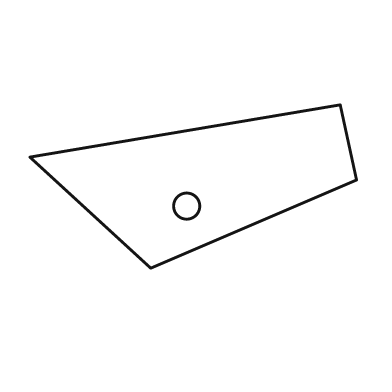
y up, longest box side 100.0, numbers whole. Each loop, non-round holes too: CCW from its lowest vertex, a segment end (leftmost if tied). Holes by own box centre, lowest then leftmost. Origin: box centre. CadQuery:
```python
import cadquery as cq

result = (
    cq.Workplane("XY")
    .moveTo(-13.0, -25.0)
    .lineTo(50.0, 2.0)
    .lineTo(45.0, 25.0)
    .lineTo(-50.0, 9.0)
    .close()
    .moveTo(-2.0, -6.0)
    .circle(4.0)
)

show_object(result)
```